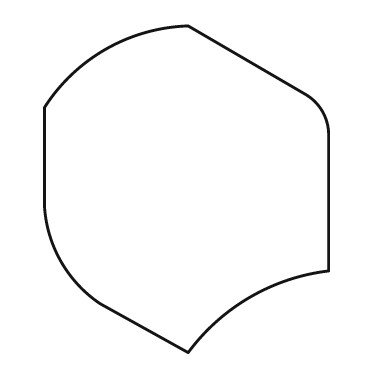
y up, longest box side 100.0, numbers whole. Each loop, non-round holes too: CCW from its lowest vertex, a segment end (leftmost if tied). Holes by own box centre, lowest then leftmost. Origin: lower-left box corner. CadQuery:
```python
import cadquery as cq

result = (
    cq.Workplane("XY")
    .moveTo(44.0, 0.0)
    .threePointArc((63.0, 17.0), (87.0, 25.0))
    .lineTo(87.0, 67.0)
    .threePointArc((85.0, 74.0), (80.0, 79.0))
    .lineTo(44.0, 100.0)
    .threePointArc((19.0, 93.0), (0.0, 75.0))
    .lineTo(0.0, 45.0)
    .threePointArc((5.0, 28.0), (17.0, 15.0))
    .close()
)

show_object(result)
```